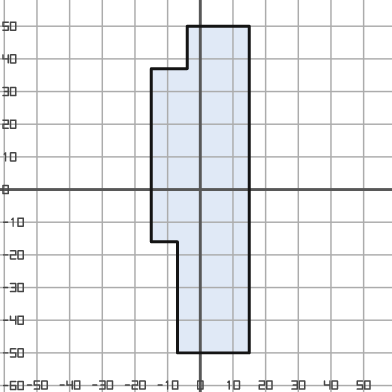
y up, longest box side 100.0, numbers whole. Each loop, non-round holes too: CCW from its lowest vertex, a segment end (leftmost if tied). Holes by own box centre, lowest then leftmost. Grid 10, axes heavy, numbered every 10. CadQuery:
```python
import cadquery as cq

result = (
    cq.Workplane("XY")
    .moveTo(-7.0, -50.0)
    .lineTo(15.0, -50.0)
    .lineTo(15.0, 50.0)
    .lineTo(-4.0, 50.0)
    .lineTo(-4.0, 37.0)
    .lineTo(-15.0, 37.0)
    .lineTo(-15.0, -16.0)
    .lineTo(-7.0, -16.0)
    .close()
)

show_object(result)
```